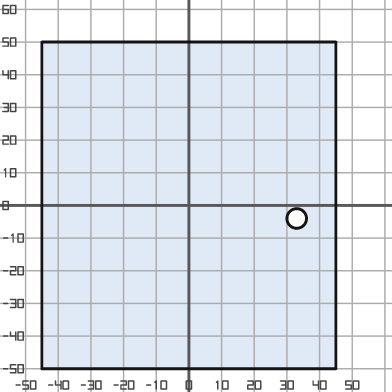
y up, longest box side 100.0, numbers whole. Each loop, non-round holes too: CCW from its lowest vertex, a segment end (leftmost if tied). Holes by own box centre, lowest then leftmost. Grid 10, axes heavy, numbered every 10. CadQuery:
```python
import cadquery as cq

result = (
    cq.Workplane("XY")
    .moveTo(-45.0, -50.0)
    .lineTo(45.0, -50.0)
    .lineTo(45.0, 50.0)
    .lineTo(-45.0, 50.0)
    .close()
    .moveTo(33.0, -4.0)
    .circle(3.0)
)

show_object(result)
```